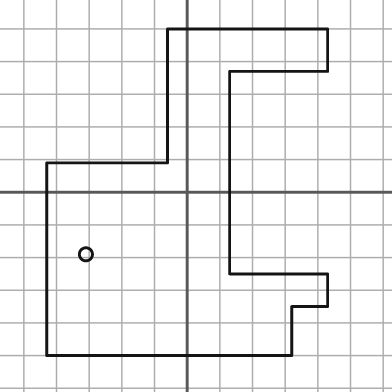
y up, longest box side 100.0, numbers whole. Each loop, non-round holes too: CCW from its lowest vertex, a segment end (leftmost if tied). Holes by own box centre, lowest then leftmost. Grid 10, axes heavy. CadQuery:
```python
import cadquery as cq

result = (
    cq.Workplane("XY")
    .moveTo(-43.0, -50.0)
    .lineTo(32.0, -50.0)
    .lineTo(32.0, -35.0)
    .lineTo(43.0, -35.0)
    .lineTo(43.0, -25.0)
    .lineTo(13.0, -25.0)
    .lineTo(13.0, 37.0)
    .lineTo(43.0, 37.0)
    .lineTo(43.0, 50.0)
    .lineTo(-6.0, 50.0)
    .lineTo(-6.0, 9.0)
    .lineTo(-43.0, 9.0)
    .close()
    .moveTo(-31.0, -19.0)
    .circle(2.0)
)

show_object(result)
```